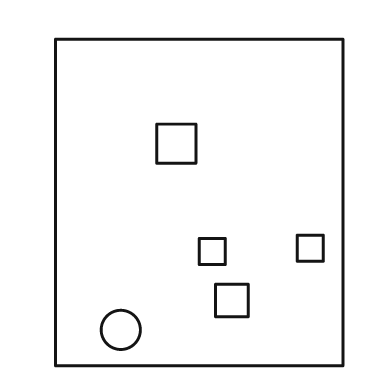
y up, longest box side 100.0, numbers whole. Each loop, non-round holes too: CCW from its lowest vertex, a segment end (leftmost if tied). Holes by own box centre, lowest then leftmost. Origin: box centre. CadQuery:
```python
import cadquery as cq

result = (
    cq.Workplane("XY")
    .moveTo(-44.0, -50.0)
    .lineTo(44.0, -50.0)
    .lineTo(44.0, 50.0)
    .lineTo(-44.0, 50.0)
    .close()
    .moveTo(-24.0, -39.0)
    .circle(6.0)
    .moveTo(5.0, -35.0)
    .lineTo(15.0, -35.0)
    .lineTo(15.0, -25.0)
    .lineTo(5.0, -25.0)
    .close()
    .moveTo(0.0, -19.0)
    .lineTo(8.0, -19.0)
    .lineTo(8.0, -11.0)
    .lineTo(0.0, -11.0)
    .close()
    .moveTo(30.0, -18.0)
    .lineTo(38.0, -18.0)
    .lineTo(38.0, -10.0)
    .lineTo(30.0, -10.0)
    .close()
    .moveTo(-13.0, 12.0)
    .lineTo(-1.0, 12.0)
    .lineTo(-1.0, 24.0)
    .lineTo(-13.0, 24.0)
    .close()
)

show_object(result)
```